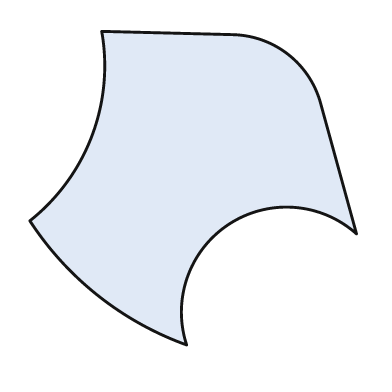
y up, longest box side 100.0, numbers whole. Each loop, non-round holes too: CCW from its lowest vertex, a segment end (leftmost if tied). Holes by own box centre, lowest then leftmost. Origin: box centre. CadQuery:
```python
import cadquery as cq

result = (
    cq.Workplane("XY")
    .moveTo(-2.0, -48.0)
    .threePointArc((11.0, -11.0), (50.0, -14.0))
    .lineTo(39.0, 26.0)
    .threePointArc((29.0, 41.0), (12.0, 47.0))
    .lineTo(-28.0, 48.0)
    .threePointArc((-31.0, 16.0), (-50.0, -10.0))
    .threePointArc((-29.0, -33.0), (-2.0, -48.0))
    .close()
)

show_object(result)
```